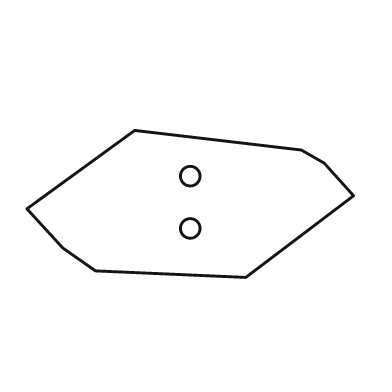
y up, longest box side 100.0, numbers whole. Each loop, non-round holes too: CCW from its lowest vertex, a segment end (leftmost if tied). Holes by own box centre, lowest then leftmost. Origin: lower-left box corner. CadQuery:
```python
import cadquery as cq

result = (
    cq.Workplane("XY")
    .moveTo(67.0, 0.0)
    .lineTo(100.0, 25.0)
    .lineTo(91.0, 35.0)
    .lineTo(84.0, 39.0)
    .lineTo(33.0, 45.0)
    .lineTo(0.0, 21.0)
    .lineTo(11.0, 9.0)
    .lineTo(21.0, 2.0)
    .close()
    .moveTo(50.0, 15.0)
    .circle(3.0)
    .moveTo(50.0, 31.0)
    .circle(3.0)
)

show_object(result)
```